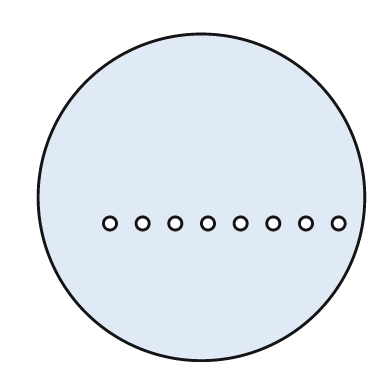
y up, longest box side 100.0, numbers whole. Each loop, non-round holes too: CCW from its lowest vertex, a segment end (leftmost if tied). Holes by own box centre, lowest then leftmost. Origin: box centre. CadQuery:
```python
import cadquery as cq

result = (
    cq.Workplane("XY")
    .moveTo(0.0, 0.0)
    .circle(50.0)
    .moveTo(-28.0, -8.0)
    .circle(2.0)
    .moveTo(-18.0, -8.0)
    .circle(2.0)
    .moveTo(-8.0, -8.0)
    .circle(2.0)
    .moveTo(2.0, -8.0)
    .circle(2.0)
    .moveTo(12.0, -8.0)
    .circle(2.0)
    .moveTo(22.0, -8.0)
    .circle(2.0)
    .moveTo(32.0, -8.0)
    .circle(2.0)
    .moveTo(42.0, -8.0)
    .circle(2.0)
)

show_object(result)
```